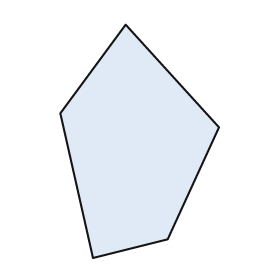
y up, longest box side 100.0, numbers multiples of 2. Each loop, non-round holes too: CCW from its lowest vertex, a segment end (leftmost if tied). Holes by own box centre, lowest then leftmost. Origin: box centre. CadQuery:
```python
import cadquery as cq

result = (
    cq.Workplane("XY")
    .moveTo(-20.0, -50.0)
    .lineTo(12.0, -42.0)
    .lineTo(34.0, 6.0)
    .lineTo(-6.0, 50.0)
    .lineTo(-34.0, 12.0)
    .close()
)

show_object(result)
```